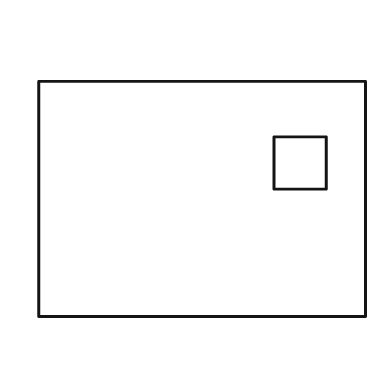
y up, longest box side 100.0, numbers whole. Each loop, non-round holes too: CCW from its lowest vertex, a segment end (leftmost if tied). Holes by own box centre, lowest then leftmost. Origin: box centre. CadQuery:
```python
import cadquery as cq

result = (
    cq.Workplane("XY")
    .moveTo(-50.0, -36.0)
    .lineTo(50.0, -36.0)
    .lineTo(50.0, 36.0)
    .lineTo(-50.0, 36.0)
    .close()
    .moveTo(22.0, 3.0)
    .lineTo(38.0, 3.0)
    .lineTo(38.0, 19.0)
    .lineTo(22.0, 19.0)
    .close()
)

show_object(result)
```